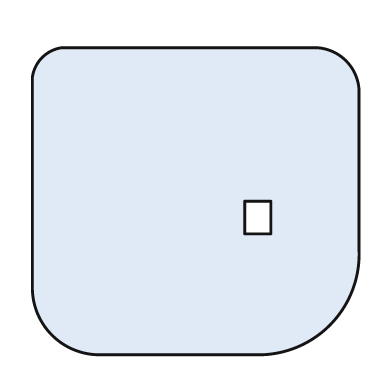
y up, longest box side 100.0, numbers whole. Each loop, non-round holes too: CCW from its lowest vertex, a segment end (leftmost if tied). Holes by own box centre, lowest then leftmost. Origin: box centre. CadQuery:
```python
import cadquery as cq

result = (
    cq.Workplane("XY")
    .moveTo(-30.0, -47.0)
    .lineTo(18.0, -47.0)
    .threePointArc((41.0, -38.0), (50.0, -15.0))
    .lineTo(50.0, 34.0)
    .threePointArc((46.0, 43.0), (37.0, 47.0))
    .lineTo(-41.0, 47.0)
    .threePointArc((-47.0, 44.0), (-50.0, 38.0))
    .lineTo(-50.0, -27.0)
    .threePointArc((-44.0, -41.0), (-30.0, -47.0))
    .close()
    .moveTo(15.0, -10.0)
    .lineTo(23.0, -10.0)
    .lineTo(23.0, 0.0)
    .lineTo(15.0, 0.0)
    .close()
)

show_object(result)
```